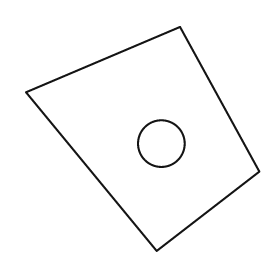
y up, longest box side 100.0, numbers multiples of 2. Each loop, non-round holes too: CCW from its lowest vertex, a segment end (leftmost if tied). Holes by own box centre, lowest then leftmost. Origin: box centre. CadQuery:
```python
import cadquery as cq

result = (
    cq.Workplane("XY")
    .moveTo(6.0, -48.0)
    .lineTo(50.0, -14.0)
    .lineTo(16.0, 48.0)
    .lineTo(-50.0, 20.0)
    .close()
    .moveTo(8.0, -2.0)
    .circle(10.0)
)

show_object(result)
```